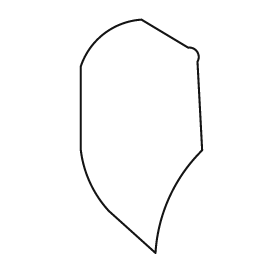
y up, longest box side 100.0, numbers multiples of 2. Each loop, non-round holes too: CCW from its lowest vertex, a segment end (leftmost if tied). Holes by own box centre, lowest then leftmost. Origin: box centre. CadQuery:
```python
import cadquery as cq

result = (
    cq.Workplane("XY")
    .moveTo(6.0, -50.0)
    .threePointArc((12.0, -26.0), (26.0, -6.0))
    .lineTo(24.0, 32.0)
    .threePointArc((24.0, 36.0), (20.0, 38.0))
    .lineTo(0.0, 50.0)
    .threePointArc((-16.0, 44.0), (-26.0, 30.0))
    .lineTo(-26.0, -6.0)
    .threePointArc((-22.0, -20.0), (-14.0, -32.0))
    .close()
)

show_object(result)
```